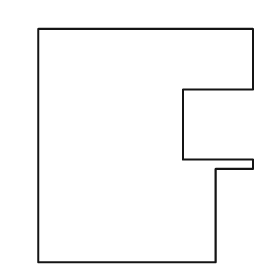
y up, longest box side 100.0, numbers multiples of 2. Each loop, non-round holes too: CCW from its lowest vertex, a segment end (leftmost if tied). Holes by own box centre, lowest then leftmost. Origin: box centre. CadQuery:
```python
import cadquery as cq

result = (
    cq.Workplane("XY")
    .moveTo(-46.0, -50.0)
    .lineTo(30.0, -50.0)
    .lineTo(30.0, -10.0)
    .lineTo(46.0, -10.0)
    .lineTo(46.0, -6.0)
    .lineTo(16.0, -6.0)
    .lineTo(16.0, 24.0)
    .lineTo(46.0, 24.0)
    .lineTo(46.0, 50.0)
    .lineTo(-46.0, 50.0)
    .close()
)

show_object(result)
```